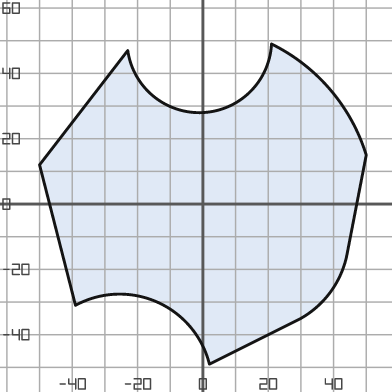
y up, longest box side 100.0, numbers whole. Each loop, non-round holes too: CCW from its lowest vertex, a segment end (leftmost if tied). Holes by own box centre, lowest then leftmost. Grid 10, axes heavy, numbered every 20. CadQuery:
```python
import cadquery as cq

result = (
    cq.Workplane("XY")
    .moveTo(2.0, -49.0)
    .lineTo(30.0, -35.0)
    .threePointArc((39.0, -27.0), (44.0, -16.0))
    .lineTo(50.0, 15.0)
    .threePointArc((39.0, 35.0), (21.0, 49.0))
    .threePointArc((0.0, 28.0), (-23.0, 47.0))
    .lineTo(-50.0, 12.0)
    .lineTo(-39.0, -31.0)
    .threePointArc((-14.0, -30.0), (2.0, -49.0))
    .close()
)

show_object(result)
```